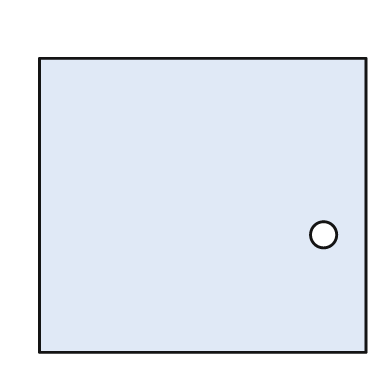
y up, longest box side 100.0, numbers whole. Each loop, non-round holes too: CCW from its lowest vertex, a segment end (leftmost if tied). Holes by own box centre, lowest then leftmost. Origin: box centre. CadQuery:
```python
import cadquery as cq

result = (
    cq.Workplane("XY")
    .moveTo(-50.0, -45.0)
    .lineTo(50.0, -45.0)
    .lineTo(50.0, 45.0)
    .lineTo(-50.0, 45.0)
    .close()
    .moveTo(37.0, -9.0)
    .circle(4.0)
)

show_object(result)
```